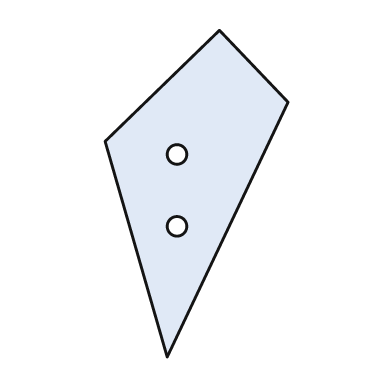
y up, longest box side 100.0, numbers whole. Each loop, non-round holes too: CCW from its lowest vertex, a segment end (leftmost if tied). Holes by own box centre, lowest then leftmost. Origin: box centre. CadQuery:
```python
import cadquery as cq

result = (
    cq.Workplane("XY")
    .moveTo(-9.0, -50.0)
    .lineTo(28.0, 28.0)
    .lineTo(7.0, 50.0)
    .lineTo(-28.0, 16.0)
    .close()
    .moveTo(-6.0, -10.0)
    .circle(3.0)
    .moveTo(-6.0, 12.0)
    .circle(3.0)
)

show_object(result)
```